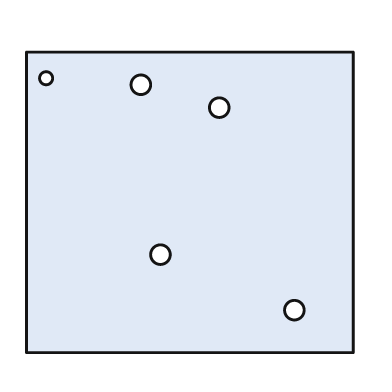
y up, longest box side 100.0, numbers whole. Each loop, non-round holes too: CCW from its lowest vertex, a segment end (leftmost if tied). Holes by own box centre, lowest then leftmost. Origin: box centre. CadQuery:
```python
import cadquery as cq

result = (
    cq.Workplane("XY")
    .moveTo(-50.0, -46.0)
    .lineTo(50.0, -46.0)
    .lineTo(50.0, 46.0)
    .lineTo(-50.0, 46.0)
    .close()
    .moveTo(32.0, -33.0)
    .circle(3.0)
    .moveTo(-9.0, -16.0)
    .circle(3.0)
    .moveTo(9.0, 29.0)
    .circle(3.0)
    .moveTo(-15.0, 36.0)
    .circle(3.0)
    .moveTo(-44.0, 38.0)
    .circle(2.0)
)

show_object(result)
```